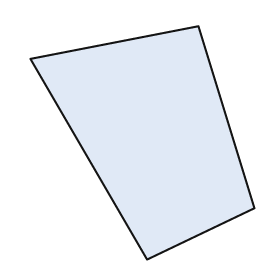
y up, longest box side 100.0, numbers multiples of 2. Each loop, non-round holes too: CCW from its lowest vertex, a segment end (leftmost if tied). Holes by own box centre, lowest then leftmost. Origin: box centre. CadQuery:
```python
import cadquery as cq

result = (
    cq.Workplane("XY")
    .moveTo(2.0, -50.0)
    .lineTo(48.0, -28.0)
    .lineTo(24.0, 50.0)
    .lineTo(-48.0, 36.0)
    .close()
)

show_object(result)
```